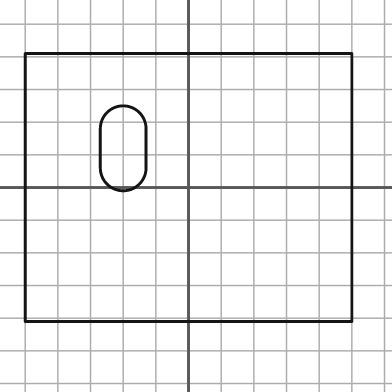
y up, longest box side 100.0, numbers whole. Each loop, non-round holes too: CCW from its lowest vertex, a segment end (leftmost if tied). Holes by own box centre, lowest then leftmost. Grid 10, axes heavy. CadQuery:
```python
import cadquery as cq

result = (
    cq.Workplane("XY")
    .moveTo(-50.0, -41.0)
    .lineTo(50.0, -41.0)
    .lineTo(50.0, 41.0)
    .lineTo(-50.0, 41.0)
    .close()
    .moveTo(-27.0, 6.0)
    .threePointArc((-20.0, -1.0), (-13.0, 6.0))
    .lineTo(-13.0, 18.0)
    .threePointArc((-20.0, 25.0), (-27.0, 18.0))
    .close()
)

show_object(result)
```